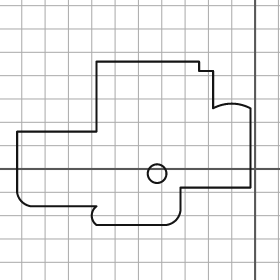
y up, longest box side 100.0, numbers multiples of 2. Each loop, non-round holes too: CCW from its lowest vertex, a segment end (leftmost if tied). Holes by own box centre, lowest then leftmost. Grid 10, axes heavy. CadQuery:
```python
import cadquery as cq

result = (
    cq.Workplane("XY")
    .moveTo(-68.0, -24.0)
    .lineTo(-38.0, -24.0)
    .threePointArc((-34.0, -22.0), (-32.0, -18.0))
    .lineTo(-32.0, -8.0)
    .lineTo(-2.0, -8.0)
    .lineTo(-2.0, 26.0)
    .threePointArc((-10.0, 28.0), (-18.0, 26.0))
    .lineTo(-18.0, 42.0)
    .lineTo(-24.0, 42.0)
    .lineTo(-24.0, 46.0)
    .lineTo(-68.0, 46.0)
    .lineTo(-68.0, 16.0)
    .lineTo(-102.0, 16.0)
    .lineTo(-102.0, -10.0)
    .threePointArc((-100.0, -14.0), (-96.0, -16.0))
    .lineTo(-68.0, -16.0)
    .threePointArc((-70.0, -20.0), (-68.0, -24.0))
    .close()
    .moveTo(-42.0, -2.0)
    .circle(4.0)
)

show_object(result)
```